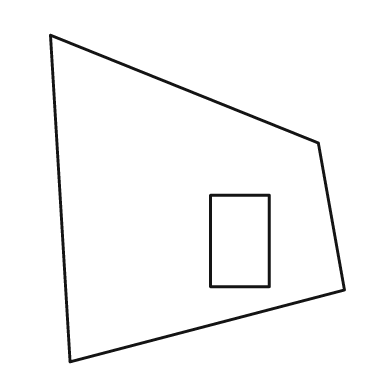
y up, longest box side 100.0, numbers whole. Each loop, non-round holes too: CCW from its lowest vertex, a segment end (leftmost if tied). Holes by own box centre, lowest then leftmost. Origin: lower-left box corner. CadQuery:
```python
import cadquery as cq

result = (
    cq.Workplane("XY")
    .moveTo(6.0, 0.0)
    .lineTo(90.0, 22.0)
    .lineTo(82.0, 67.0)
    .lineTo(0.0, 100.0)
    .close()
    .moveTo(49.0, 23.0)
    .lineTo(67.0, 23.0)
    .lineTo(67.0, 51.0)
    .lineTo(49.0, 51.0)
    .close()
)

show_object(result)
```